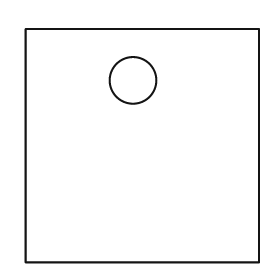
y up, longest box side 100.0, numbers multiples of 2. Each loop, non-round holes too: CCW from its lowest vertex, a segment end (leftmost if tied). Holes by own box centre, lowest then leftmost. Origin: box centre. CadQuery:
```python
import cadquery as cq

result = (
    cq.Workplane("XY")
    .moveTo(-50.0, -50.0)
    .lineTo(50.0, -50.0)
    .lineTo(50.0, 50.0)
    .lineTo(-50.0, 50.0)
    .close()
    .moveTo(-4.0, 28.0)
    .circle(10.0)
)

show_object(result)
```